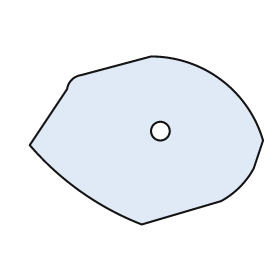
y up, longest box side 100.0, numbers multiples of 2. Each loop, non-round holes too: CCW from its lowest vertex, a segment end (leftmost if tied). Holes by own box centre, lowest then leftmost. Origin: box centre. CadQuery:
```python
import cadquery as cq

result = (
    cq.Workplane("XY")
    .moveTo(-2.0, -36.0)
    .lineTo(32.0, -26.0)
    .threePointArc((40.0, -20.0), (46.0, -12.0))
    .lineTo(50.0, 0.0)
    .threePointArc((32.0, 26.0), (2.0, 36.0))
    .lineTo(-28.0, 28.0)
    .threePointArc((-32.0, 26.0), (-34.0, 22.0))
    .lineTo(-50.0, -2.0)
    .threePointArc((-28.0, -22.0), (-2.0, -36.0))
    .close()
    .moveTo(6.0, 4.0)
    .circle(4.0)
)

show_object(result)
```